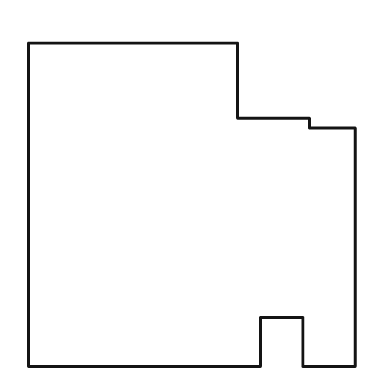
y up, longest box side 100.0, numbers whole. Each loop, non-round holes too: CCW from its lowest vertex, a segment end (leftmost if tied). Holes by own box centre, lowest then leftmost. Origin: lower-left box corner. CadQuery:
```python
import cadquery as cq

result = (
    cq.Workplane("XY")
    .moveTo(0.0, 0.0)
    .lineTo(71.0, 0.0)
    .lineTo(71.0, 15.0)
    .lineTo(84.0, 15.0)
    .lineTo(84.0, 0.0)
    .lineTo(100.0, 0.0)
    .lineTo(100.0, 73.0)
    .lineTo(86.0, 73.0)
    .lineTo(86.0, 76.0)
    .lineTo(64.0, 76.0)
    .lineTo(64.0, 99.0)
    .lineTo(0.0, 99.0)
    .close()
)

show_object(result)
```